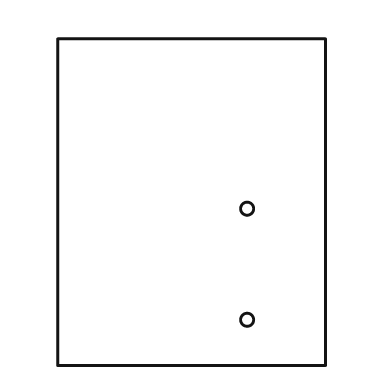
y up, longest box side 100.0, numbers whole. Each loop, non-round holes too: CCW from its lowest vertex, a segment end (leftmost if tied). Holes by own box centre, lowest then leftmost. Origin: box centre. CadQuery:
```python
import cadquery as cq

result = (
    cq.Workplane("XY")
    .moveTo(-41.0, -50.0)
    .lineTo(41.0, -50.0)
    .lineTo(41.0, 50.0)
    .lineTo(-41.0, 50.0)
    .close()
    .moveTo(17.0, -36.0)
    .circle(2.0)
    .moveTo(17.0, -2.0)
    .circle(2.0)
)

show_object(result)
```